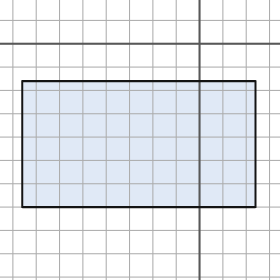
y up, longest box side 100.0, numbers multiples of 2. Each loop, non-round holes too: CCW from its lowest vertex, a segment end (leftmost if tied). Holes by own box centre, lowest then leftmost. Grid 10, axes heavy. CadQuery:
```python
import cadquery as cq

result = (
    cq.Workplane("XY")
    .moveTo(-76.0, -70.0)
    .lineTo(24.0, -70.0)
    .lineTo(24.0, -16.0)
    .lineTo(-76.0, -16.0)
    .close()
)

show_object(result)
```